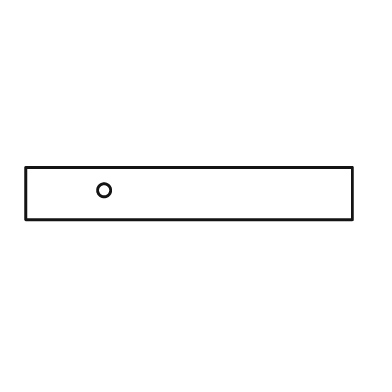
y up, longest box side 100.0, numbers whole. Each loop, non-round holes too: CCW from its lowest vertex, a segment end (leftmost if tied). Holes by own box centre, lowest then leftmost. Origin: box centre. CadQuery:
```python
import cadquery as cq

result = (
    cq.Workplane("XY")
    .moveTo(-50.0, -8.0)
    .lineTo(50.0, -8.0)
    .lineTo(50.0, 8.0)
    .lineTo(-50.0, 8.0)
    .close()
    .moveTo(-26.0, 1.0)
    .circle(2.0)
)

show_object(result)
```